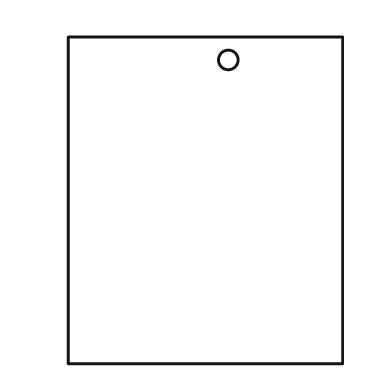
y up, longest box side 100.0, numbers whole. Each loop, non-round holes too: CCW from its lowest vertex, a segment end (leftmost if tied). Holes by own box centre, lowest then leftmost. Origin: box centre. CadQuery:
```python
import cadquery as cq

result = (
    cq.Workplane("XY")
    .moveTo(-42.0, -50.0)
    .lineTo(42.0, -50.0)
    .lineTo(42.0, 50.0)
    .lineTo(-42.0, 50.0)
    .close()
    .moveTo(7.0, 43.0)
    .circle(3.0)
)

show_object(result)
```